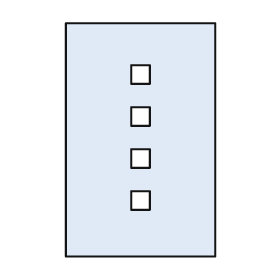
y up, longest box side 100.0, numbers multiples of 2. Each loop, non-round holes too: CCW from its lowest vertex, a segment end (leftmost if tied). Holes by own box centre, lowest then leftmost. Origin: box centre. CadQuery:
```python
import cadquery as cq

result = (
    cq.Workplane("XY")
    .moveTo(-32.0, -50.0)
    .lineTo(32.0, -50.0)
    .lineTo(32.0, 50.0)
    .lineTo(-32.0, 50.0)
    .close()
    .moveTo(-4.0, -30.0)
    .lineTo(4.0, -30.0)
    .lineTo(4.0, -22.0)
    .lineTo(-4.0, -22.0)
    .close()
    .moveTo(-4.0, -12.0)
    .lineTo(4.0, -12.0)
    .lineTo(4.0, -4.0)
    .lineTo(-4.0, -4.0)
    .close()
    .moveTo(-4.0, 6.0)
    .lineTo(4.0, 6.0)
    .lineTo(4.0, 14.0)
    .lineTo(-4.0, 14.0)
    .close()
    .moveTo(-4.0, 24.0)
    .lineTo(4.0, 24.0)
    .lineTo(4.0, 32.0)
    .lineTo(-4.0, 32.0)
    .close()
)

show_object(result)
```